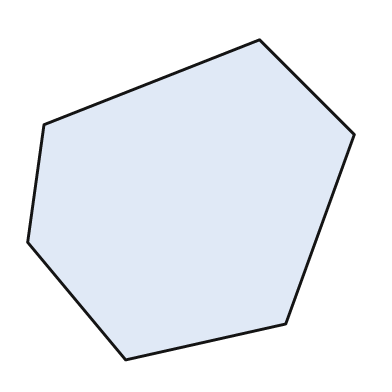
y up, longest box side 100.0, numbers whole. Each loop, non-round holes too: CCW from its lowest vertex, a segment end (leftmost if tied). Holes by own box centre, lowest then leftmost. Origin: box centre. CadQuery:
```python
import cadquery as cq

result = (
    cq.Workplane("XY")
    .moveTo(-20.0, -49.0)
    .lineTo(29.0, -38.0)
    .lineTo(50.0, 20.0)
    .lineTo(21.0, 49.0)
    .lineTo(-45.0, 23.0)
    .lineTo(-50.0, -13.0)
    .close()
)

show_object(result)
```